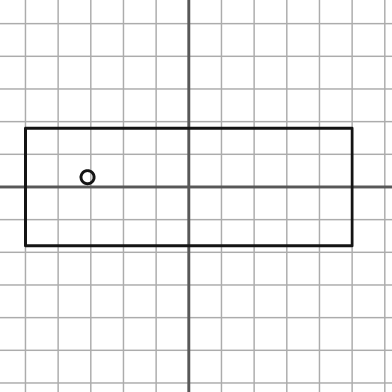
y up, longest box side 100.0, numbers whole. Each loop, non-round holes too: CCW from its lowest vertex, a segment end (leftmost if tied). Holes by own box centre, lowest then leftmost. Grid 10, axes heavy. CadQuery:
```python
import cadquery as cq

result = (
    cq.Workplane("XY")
    .moveTo(-50.0, -18.0)
    .lineTo(50.0, -18.0)
    .lineTo(50.0, 18.0)
    .lineTo(-50.0, 18.0)
    .close()
    .moveTo(-31.0, 3.0)
    .circle(2.0)
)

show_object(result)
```